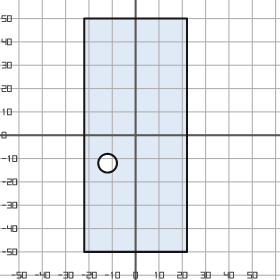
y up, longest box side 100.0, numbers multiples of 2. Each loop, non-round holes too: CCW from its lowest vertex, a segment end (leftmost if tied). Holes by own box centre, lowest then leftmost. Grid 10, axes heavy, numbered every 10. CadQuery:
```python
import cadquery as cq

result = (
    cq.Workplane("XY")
    .moveTo(-22.0, -50.0)
    .lineTo(22.0, -50.0)
    .lineTo(22.0, 50.0)
    .lineTo(-22.0, 50.0)
    .close()
    .moveTo(-12.0, -12.0)
    .circle(4.0)
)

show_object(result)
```